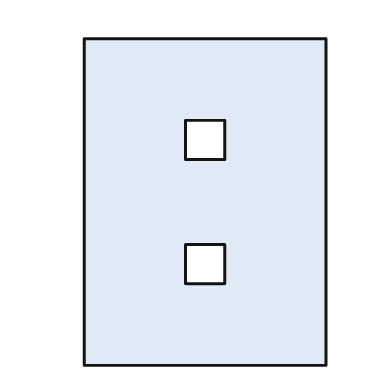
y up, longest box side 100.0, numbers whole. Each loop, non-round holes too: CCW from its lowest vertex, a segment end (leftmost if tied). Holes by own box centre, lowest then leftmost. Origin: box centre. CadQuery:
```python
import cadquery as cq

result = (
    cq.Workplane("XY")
    .moveTo(-37.0, -50.0)
    .lineTo(37.0, -50.0)
    .lineTo(37.0, 50.0)
    .lineTo(-37.0, 50.0)
    .close()
    .moveTo(-6.0, -25.0)
    .lineTo(6.0, -25.0)
    .lineTo(6.0, -13.0)
    .lineTo(-6.0, -13.0)
    .close()
    .moveTo(-6.0, 13.0)
    .lineTo(6.0, 13.0)
    .lineTo(6.0, 25.0)
    .lineTo(-6.0, 25.0)
    .close()
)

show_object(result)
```